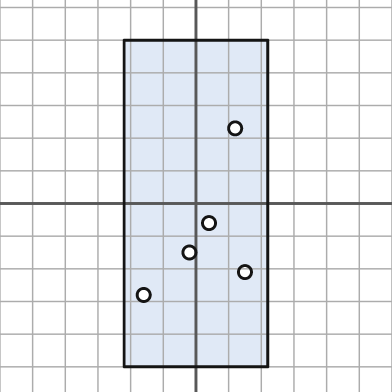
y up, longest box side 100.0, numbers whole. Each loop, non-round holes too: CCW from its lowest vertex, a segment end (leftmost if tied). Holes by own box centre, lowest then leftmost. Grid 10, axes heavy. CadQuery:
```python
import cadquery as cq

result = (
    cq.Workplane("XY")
    .moveTo(-22.0, -50.0)
    .lineTo(22.0, -50.0)
    .lineTo(22.0, 50.0)
    .lineTo(-22.0, 50.0)
    .close()
    .moveTo(-16.0, -28.0)
    .circle(2.0)
    .moveTo(15.0, -21.0)
    .circle(2.0)
    .moveTo(-2.0, -15.0)
    .circle(2.0)
    .moveTo(4.0, -6.0)
    .circle(2.0)
    .moveTo(12.0, 23.0)
    .circle(2.0)
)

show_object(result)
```